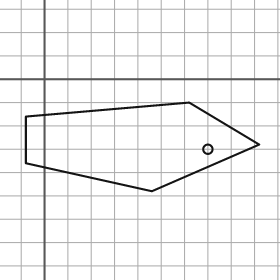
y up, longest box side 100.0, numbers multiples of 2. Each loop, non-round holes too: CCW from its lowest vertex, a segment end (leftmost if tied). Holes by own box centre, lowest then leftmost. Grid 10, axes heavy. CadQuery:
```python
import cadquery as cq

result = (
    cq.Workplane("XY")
    .moveTo(46.0, -48.0)
    .lineTo(92.0, -28.0)
    .lineTo(62.0, -10.0)
    .lineTo(-8.0, -16.0)
    .lineTo(-8.0, -36.0)
    .close()
    .moveTo(70.0, -30.0)
    .circle(2.0)
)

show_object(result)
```